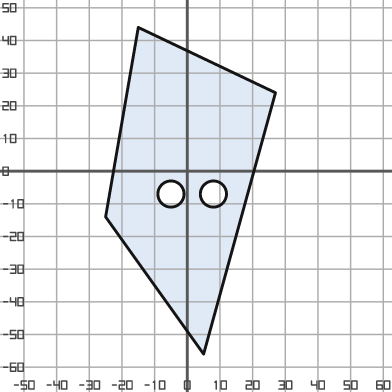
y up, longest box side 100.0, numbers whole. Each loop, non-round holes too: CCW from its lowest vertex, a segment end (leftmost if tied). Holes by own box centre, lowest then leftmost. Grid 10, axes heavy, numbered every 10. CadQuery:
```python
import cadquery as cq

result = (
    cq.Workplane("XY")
    .moveTo(5.0, -56.0)
    .lineTo(27.0, 24.0)
    .lineTo(-15.0, 44.0)
    .lineTo(-25.0, -14.0)
    .close()
    .moveTo(-5.0, -7.0)
    .circle(4.0)
    .moveTo(8.0, -7.0)
    .circle(4.0)
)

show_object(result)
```